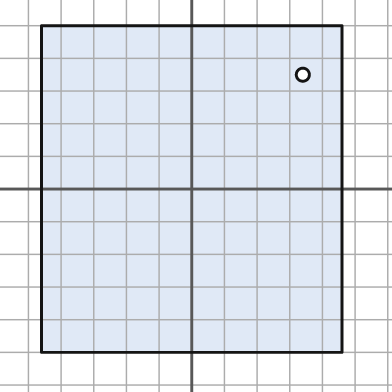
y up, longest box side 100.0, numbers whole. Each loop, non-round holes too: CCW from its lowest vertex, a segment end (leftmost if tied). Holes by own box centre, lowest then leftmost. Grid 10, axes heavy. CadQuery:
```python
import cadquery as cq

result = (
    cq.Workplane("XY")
    .moveTo(-46.0, -50.0)
    .lineTo(46.0, -50.0)
    .lineTo(46.0, 50.0)
    .lineTo(-46.0, 50.0)
    .close()
    .moveTo(34.0, 35.0)
    .circle(2.0)
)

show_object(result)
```